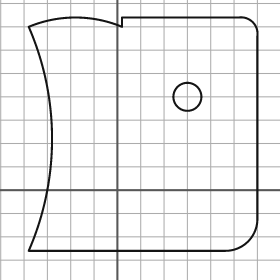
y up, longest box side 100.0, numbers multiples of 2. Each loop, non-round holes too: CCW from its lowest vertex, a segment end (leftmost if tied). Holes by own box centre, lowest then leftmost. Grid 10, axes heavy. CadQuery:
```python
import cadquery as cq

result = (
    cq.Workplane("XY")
    .moveTo(-38.0, -26.0)
    .lineTo(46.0, -26.0)
    .threePointArc((56.0, -22.0), (60.0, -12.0))
    .lineTo(60.0, 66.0)
    .threePointArc((58.0, 72.0), (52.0, 74.0))
    .lineTo(2.0, 74.0)
    .lineTo(2.0, 70.0)
    .threePointArc((-18.0, 74.0), (-38.0, 70.0))
    .threePointArc((-28.0, 22.0), (-38.0, -26.0))
    .close()
    .moveTo(30.0, 40.0)
    .circle(6.0)
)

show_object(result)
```